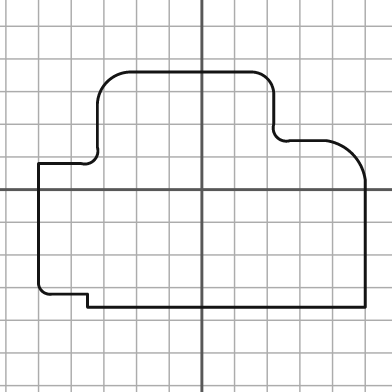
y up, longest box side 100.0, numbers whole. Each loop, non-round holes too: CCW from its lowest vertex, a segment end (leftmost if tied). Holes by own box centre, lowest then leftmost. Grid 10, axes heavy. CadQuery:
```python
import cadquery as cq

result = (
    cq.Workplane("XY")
    .moveTo(-35.0, -36.0)
    .lineTo(50.0, -36.0)
    .lineTo(50.0, 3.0)
    .threePointArc((46.0, 11.0), (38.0, 15.0))
    .lineTo(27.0, 15.0)
    .threePointArc((23.0, 16.0), (22.0, 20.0))
    .lineTo(22.0, 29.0)
    .threePointArc((20.0, 34.0), (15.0, 36.0))
    .lineTo(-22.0, 36.0)
    .threePointArc((-29.0, 33.0), (-32.0, 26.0))
    .lineTo(-32.0, 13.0)
    .threePointArc((-33.0, 9.0), (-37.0, 8.0))
    .lineTo(-50.0, 8.0)
    .lineTo(-50.0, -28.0)
    .threePointArc((-49.0, -31.0), (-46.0, -32.0))
    .lineTo(-35.0, -32.0)
    .close()
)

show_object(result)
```